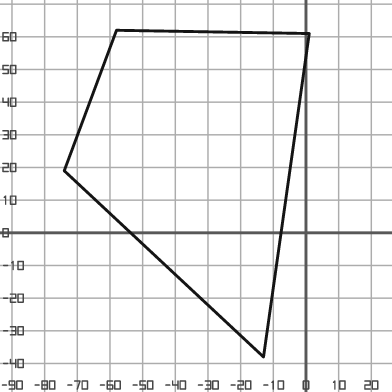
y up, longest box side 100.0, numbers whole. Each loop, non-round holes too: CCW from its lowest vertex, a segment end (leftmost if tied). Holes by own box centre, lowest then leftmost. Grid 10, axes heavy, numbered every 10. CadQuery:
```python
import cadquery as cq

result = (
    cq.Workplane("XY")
    .moveTo(-13.0, -38.0)
    .lineTo(1.0, 61.0)
    .lineTo(-58.0, 62.0)
    .lineTo(-74.0, 19.0)
    .close()
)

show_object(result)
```